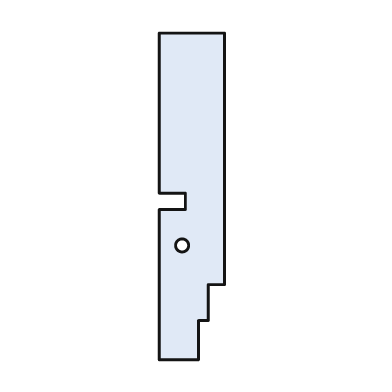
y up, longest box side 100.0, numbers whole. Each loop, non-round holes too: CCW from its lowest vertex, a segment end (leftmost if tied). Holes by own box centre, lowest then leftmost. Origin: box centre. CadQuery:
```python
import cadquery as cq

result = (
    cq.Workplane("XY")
    .moveTo(-10.0, -50.0)
    .lineTo(2.0, -50.0)
    .lineTo(2.0, -38.0)
    .lineTo(5.0, -38.0)
    .lineTo(5.0, -27.0)
    .lineTo(10.0, -27.0)
    .lineTo(10.0, 50.0)
    .lineTo(-10.0, 50.0)
    .lineTo(-10.0, 1.0)
    .lineTo(-2.0, 1.0)
    .lineTo(-2.0, -4.0)
    .lineTo(-10.0, -4.0)
    .close()
    .moveTo(-3.0, -15.0)
    .circle(2.0)
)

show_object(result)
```